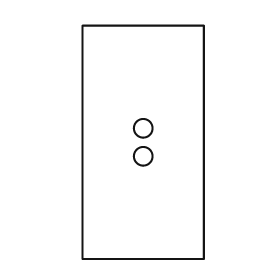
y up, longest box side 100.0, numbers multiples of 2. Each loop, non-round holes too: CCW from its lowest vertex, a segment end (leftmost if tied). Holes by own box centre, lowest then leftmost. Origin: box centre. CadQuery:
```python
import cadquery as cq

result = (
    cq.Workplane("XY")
    .moveTo(-26.0, -50.0)
    .lineTo(26.0, -50.0)
    .lineTo(26.0, 50.0)
    .lineTo(-26.0, 50.0)
    .close()
    .moveTo(0.0, -6.0)
    .circle(4.0)
    .moveTo(0.0, 6.0)
    .circle(4.0)
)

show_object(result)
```